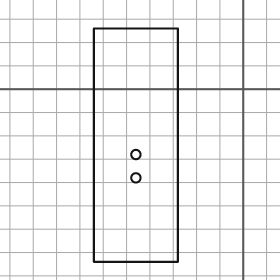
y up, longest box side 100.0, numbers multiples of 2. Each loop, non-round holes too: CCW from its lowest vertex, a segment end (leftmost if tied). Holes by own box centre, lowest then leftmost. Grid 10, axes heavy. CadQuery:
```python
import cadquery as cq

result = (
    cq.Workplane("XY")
    .moveTo(-64.0, -74.0)
    .lineTo(-28.0, -74.0)
    .lineTo(-28.0, 26.0)
    .lineTo(-64.0, 26.0)
    .close()
    .moveTo(-46.0, -38.0)
    .circle(2.0)
    .moveTo(-46.0, -28.0)
    .circle(2.0)
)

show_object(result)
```